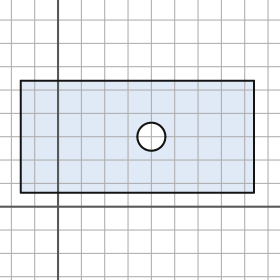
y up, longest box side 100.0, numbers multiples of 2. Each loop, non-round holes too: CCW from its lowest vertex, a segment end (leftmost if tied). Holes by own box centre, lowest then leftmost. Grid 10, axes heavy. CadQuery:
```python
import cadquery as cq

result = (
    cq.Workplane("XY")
    .moveTo(-16.0, 6.0)
    .lineTo(84.0, 6.0)
    .lineTo(84.0, 54.0)
    .lineTo(-16.0, 54.0)
    .close()
    .moveTo(40.0, 30.0)
    .circle(6.0)
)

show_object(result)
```